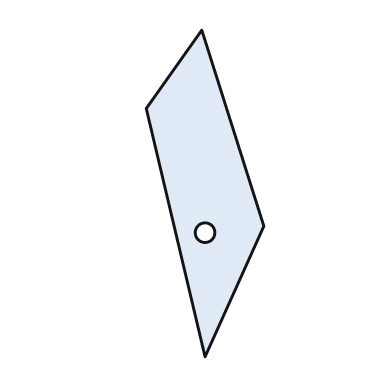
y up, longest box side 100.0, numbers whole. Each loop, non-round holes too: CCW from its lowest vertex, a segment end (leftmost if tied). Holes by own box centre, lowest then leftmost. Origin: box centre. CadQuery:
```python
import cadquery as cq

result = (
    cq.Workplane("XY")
    .moveTo(0.0, -50.0)
    .lineTo(18.0, -10.0)
    .lineTo(-1.0, 50.0)
    .lineTo(-18.0, 26.0)
    .close()
    .moveTo(0.0, -12.0)
    .circle(3.0)
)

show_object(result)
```